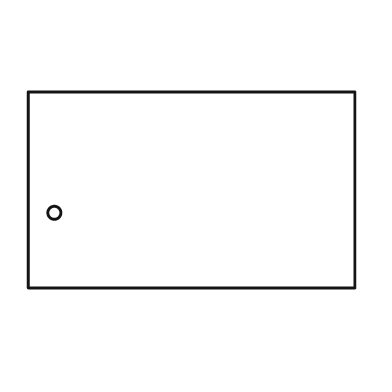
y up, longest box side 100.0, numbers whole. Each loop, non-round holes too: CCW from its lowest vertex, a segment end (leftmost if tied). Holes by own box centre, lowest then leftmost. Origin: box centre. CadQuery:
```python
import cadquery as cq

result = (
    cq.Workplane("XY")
    .moveTo(-50.0, -30.0)
    .lineTo(50.0, -30.0)
    .lineTo(50.0, 30.0)
    .lineTo(-50.0, 30.0)
    .close()
    .moveTo(-42.0, -7.0)
    .circle(2.0)
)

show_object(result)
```